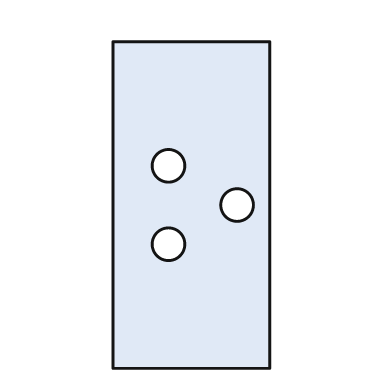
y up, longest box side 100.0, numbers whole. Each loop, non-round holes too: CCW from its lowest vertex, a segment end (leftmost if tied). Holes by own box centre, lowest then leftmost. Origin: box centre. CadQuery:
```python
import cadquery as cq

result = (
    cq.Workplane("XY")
    .moveTo(-24.0, -50.0)
    .lineTo(24.0, -50.0)
    .lineTo(24.0, 50.0)
    .lineTo(-24.0, 50.0)
    .close()
    .moveTo(-7.0, -12.0)
    .circle(5.0)
    .moveTo(14.0, 0.0)
    .circle(5.0)
    .moveTo(-7.0, 12.0)
    .circle(5.0)
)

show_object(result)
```